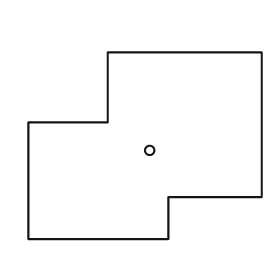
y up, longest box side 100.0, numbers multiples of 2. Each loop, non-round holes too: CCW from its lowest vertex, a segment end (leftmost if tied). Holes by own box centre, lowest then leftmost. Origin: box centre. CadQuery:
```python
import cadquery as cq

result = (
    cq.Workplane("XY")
    .moveTo(-50.0, -40.0)
    .lineTo(10.0, -40.0)
    .lineTo(10.0, -22.0)
    .lineTo(50.0, -22.0)
    .lineTo(50.0, 40.0)
    .lineTo(-16.0, 40.0)
    .lineTo(-16.0, 10.0)
    .lineTo(-50.0, 10.0)
    .close()
    .moveTo(2.0, -2.0)
    .circle(2.0)
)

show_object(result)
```